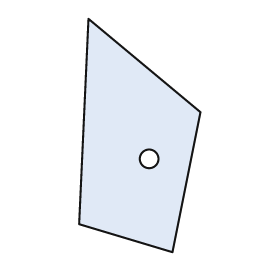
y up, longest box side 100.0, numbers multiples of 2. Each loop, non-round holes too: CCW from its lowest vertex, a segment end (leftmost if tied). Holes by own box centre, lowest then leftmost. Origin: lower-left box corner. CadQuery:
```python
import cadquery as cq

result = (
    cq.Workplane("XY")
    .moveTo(40.0, 0.0)
    .lineTo(52.0, 60.0)
    .lineTo(4.0, 100.0)
    .lineTo(0.0, 12.0)
    .close()
    .moveTo(30.0, 40.0)
    .circle(4.0)
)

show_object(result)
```